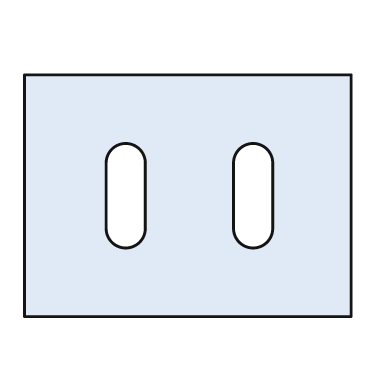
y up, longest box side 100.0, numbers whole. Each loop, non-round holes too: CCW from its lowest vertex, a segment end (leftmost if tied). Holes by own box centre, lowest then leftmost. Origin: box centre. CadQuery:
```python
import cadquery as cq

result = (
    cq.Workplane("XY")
    .moveTo(-50.0, -37.0)
    .lineTo(50.0, -37.0)
    .lineTo(50.0, 37.0)
    .lineTo(-50.0, 37.0)
    .close()
    .moveTo(-25.0, -10.0)
    .threePointArc((-19.0, -16.0), (-13.0, -10.0))
    .lineTo(-13.0, 10.0)
    .threePointArc((-19.0, 16.0), (-25.0, 10.0))
    .close()
    .moveTo(14.0, -10.0)
    .threePointArc((20.0, -16.0), (26.0, -10.0))
    .lineTo(26.0, 10.0)
    .threePointArc((20.0, 16.0), (14.0, 10.0))
    .close()
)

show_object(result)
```